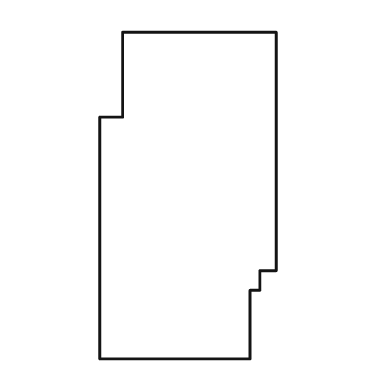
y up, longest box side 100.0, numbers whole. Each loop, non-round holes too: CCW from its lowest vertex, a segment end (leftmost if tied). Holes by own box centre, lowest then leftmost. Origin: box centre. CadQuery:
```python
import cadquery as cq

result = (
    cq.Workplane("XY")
    .moveTo(-27.0, -50.0)
    .lineTo(19.0, -50.0)
    .lineTo(19.0, -29.0)
    .lineTo(22.0, -29.0)
    .lineTo(22.0, -23.0)
    .lineTo(27.0, -23.0)
    .lineTo(27.0, 50.0)
    .lineTo(-20.0, 50.0)
    .lineTo(-20.0, 24.0)
    .lineTo(-27.0, 24.0)
    .close()
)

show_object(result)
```